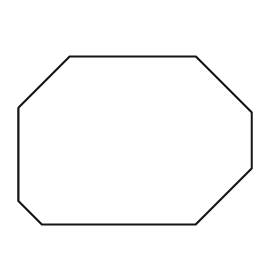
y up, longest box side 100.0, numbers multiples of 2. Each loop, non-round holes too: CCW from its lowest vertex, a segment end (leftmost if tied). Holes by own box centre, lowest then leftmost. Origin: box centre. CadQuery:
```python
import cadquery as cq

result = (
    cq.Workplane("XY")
    .moveTo(-40.0, -36.0)
    .lineTo(26.0, -36.0)
    .lineTo(50.0, -12.0)
    .lineTo(50.0, 12.0)
    .lineTo(26.0, 36.0)
    .lineTo(-28.0, 36.0)
    .lineTo(-50.0, 14.0)
    .lineTo(-50.0, -26.0)
    .close()
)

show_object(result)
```